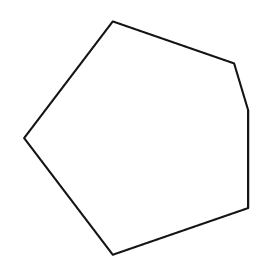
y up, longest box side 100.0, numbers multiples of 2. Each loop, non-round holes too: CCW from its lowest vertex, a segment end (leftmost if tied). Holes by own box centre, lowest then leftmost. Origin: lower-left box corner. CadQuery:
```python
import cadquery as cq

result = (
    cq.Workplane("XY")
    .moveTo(38.0, 0.0)
    .lineTo(96.0, 20.0)
    .lineTo(96.0, 62.0)
    .lineTo(90.0, 82.0)
    .lineTo(38.0, 100.0)
    .lineTo(0.0, 50.0)
    .close()
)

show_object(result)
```